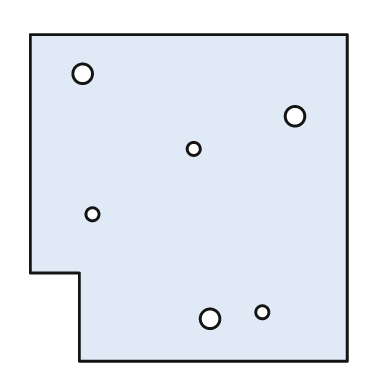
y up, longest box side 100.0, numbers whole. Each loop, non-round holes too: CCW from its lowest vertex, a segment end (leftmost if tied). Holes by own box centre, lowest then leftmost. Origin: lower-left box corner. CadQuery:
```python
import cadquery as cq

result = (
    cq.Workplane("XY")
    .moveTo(15.0, 0.0)
    .lineTo(97.0, 0.0)
    .lineTo(97.0, 100.0)
    .lineTo(0.0, 100.0)
    .lineTo(0.0, 27.0)
    .lineTo(15.0, 27.0)
    .close()
    .moveTo(55.0, 13.0)
    .circle(3.0)
    .moveTo(71.0, 15.0)
    .circle(2.0)
    .moveTo(19.0, 45.0)
    .circle(2.0)
    .moveTo(50.0, 65.0)
    .circle(2.0)
    .moveTo(81.0, 75.0)
    .circle(3.0)
    .moveTo(16.0, 88.0)
    .circle(3.0)
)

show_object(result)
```